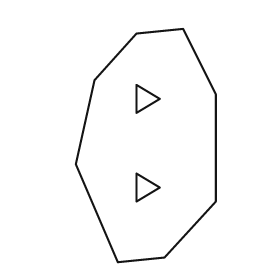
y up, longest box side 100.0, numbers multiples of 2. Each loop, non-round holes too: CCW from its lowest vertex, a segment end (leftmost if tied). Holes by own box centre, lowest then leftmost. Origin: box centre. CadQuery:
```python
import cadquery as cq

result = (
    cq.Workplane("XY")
    .moveTo(-12.0, -50.0)
    .lineTo(8.0, -48.0)
    .lineTo(30.0, -24.0)
    .lineTo(30.0, 22.0)
    .lineTo(16.0, 50.0)
    .lineTo(-4.0, 48.0)
    .lineTo(-22.0, 28.0)
    .lineTo(-30.0, -8.0)
    .close()
    .moveTo(-4.0, -24.0)
    .lineTo(6.0, -18.0)
    .lineTo(-4.0, -12.0)
    .close()
    .moveTo(-4.0, 14.0)
    .lineTo(6.0, 20.0)
    .lineTo(-4.0, 26.0)
    .close()
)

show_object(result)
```